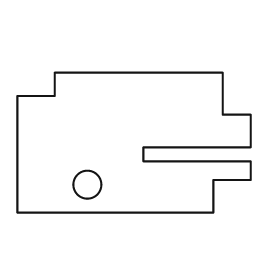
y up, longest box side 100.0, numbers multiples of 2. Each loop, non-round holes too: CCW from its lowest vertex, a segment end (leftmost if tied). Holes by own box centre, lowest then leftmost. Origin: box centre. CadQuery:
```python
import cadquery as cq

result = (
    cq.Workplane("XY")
    .moveTo(-50.0, -30.0)
    .lineTo(34.0, -30.0)
    .lineTo(34.0, -16.0)
    .lineTo(50.0, -16.0)
    .lineTo(50.0, -8.0)
    .lineTo(4.0, -8.0)
    .lineTo(4.0, -2.0)
    .lineTo(50.0, -2.0)
    .lineTo(50.0, 12.0)
    .lineTo(38.0, 12.0)
    .lineTo(38.0, 30.0)
    .lineTo(-34.0, 30.0)
    .lineTo(-34.0, 20.0)
    .lineTo(-50.0, 20.0)
    .close()
    .moveTo(-20.0, -18.0)
    .circle(6.0)
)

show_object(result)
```